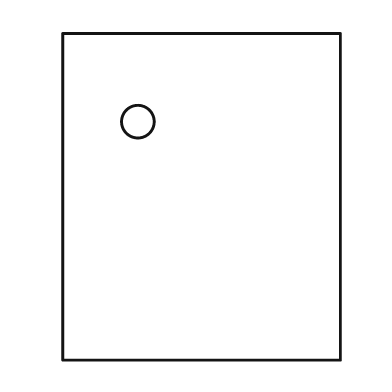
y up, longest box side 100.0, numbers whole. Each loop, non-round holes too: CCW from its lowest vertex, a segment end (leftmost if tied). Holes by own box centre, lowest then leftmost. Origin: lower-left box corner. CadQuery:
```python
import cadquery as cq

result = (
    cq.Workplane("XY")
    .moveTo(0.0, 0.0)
    .lineTo(85.0, 0.0)
    .lineTo(85.0, 100.0)
    .lineTo(0.0, 100.0)
    .close()
    .moveTo(23.0, 73.0)
    .circle(5.0)
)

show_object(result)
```